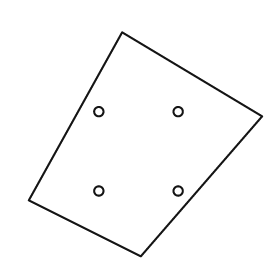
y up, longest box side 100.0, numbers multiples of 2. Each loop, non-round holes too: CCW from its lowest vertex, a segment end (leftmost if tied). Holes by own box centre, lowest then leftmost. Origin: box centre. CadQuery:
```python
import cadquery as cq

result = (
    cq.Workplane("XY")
    .moveTo(-2.0, -48.0)
    .lineTo(50.0, 12.0)
    .lineTo(-10.0, 48.0)
    .lineTo(-50.0, -24.0)
    .close()
    .moveTo(-20.0, -20.0)
    .circle(2.0)
    .moveTo(14.0, -20.0)
    .circle(2.0)
    .moveTo(-20.0, 14.0)
    .circle(2.0)
    .moveTo(14.0, 14.0)
    .circle(2.0)
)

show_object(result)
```